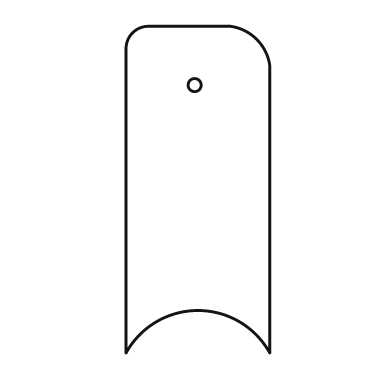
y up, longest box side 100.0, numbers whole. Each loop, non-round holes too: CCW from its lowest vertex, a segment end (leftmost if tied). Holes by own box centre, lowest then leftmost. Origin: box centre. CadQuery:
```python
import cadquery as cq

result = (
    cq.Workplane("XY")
    .moveTo(-22.0, -50.0)
    .threePointArc((0.0, -37.0), (22.0, -50.0))
    .lineTo(22.0, 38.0)
    .threePointArc((18.0, 46.0), (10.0, 50.0))
    .lineTo(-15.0, 50.0)
    .threePointArc((-20.0, 48.0), (-22.0, 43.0))
    .close()
    .moveTo(-1.0, 32.0)
    .circle(2.0)
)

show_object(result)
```